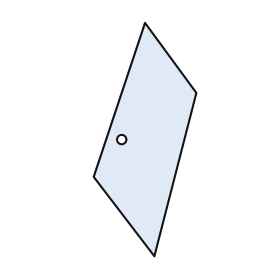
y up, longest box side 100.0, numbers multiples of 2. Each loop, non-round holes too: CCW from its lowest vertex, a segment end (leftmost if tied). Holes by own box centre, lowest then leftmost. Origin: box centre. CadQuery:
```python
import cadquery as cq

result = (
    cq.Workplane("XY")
    .moveTo(4.0, -50.0)
    .lineTo(22.0, 20.0)
    .lineTo(0.0, 50.0)
    .lineTo(-22.0, -16.0)
    .close()
    .moveTo(-10.0, 0.0)
    .circle(2.0)
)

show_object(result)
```